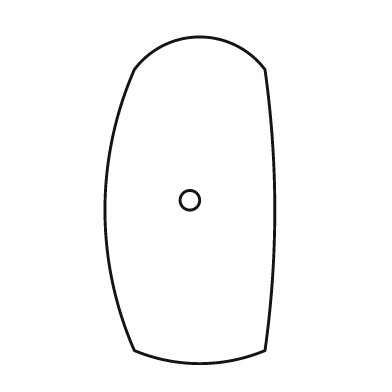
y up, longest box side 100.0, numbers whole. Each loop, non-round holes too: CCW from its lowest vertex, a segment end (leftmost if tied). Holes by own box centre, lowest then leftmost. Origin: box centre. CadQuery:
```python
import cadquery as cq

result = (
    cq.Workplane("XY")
    .moveTo(-17.0, -46.0)
    .threePointArc((3.0, -50.0), (23.0, -46.0))
    .threePointArc((26.0, -3.0), (23.0, 40.0))
    .threePointArc((3.0, 50.0), (-17.0, 40.0))
    .threePointArc((-26.0, -3.0), (-17.0, -46.0))
    .close()
    .moveTo(0.0, 0.0)
    .circle(3.0)
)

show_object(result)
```